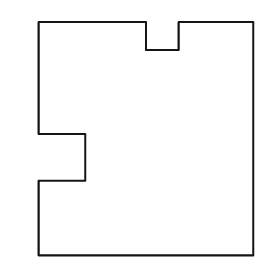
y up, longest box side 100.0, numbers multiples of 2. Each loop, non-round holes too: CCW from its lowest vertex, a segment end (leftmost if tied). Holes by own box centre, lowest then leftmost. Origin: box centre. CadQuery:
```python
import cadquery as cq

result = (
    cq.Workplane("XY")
    .moveTo(-46.0, -50.0)
    .lineTo(46.0, -50.0)
    .lineTo(46.0, 50.0)
    .lineTo(14.0, 50.0)
    .lineTo(14.0, 38.0)
    .lineTo(0.0, 38.0)
    .lineTo(0.0, 50.0)
    .lineTo(-46.0, 50.0)
    .lineTo(-46.0, 2.0)
    .lineTo(-26.0, 2.0)
    .lineTo(-26.0, -18.0)
    .lineTo(-46.0, -18.0)
    .close()
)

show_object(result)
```